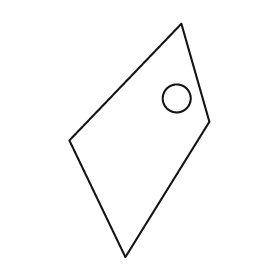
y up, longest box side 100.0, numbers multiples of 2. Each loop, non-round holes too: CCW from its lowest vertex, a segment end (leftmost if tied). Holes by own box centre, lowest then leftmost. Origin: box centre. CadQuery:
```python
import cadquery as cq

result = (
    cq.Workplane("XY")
    .moveTo(-6.0, -50.0)
    .lineTo(30.0, 8.0)
    .lineTo(18.0, 50.0)
    .lineTo(-30.0, 0.0)
    .close()
    .moveTo(16.0, 18.0)
    .circle(6.0)
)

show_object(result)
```